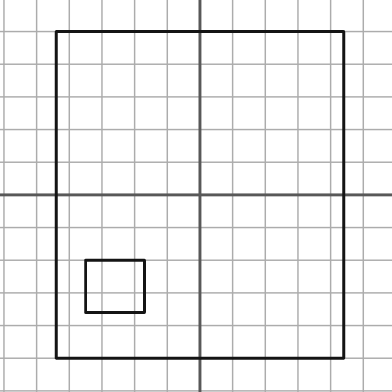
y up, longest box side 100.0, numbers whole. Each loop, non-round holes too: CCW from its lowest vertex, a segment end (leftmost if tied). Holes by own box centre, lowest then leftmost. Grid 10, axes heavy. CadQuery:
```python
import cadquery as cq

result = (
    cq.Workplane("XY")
    .moveTo(-44.0, -50.0)
    .lineTo(44.0, -50.0)
    .lineTo(44.0, 50.0)
    .lineTo(-44.0, 50.0)
    .close()
    .moveTo(-35.0, -36.0)
    .lineTo(-17.0, -36.0)
    .lineTo(-17.0, -20.0)
    .lineTo(-35.0, -20.0)
    .close()
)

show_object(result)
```